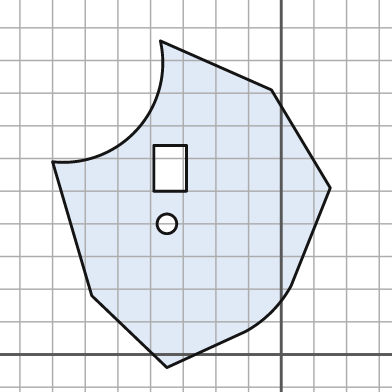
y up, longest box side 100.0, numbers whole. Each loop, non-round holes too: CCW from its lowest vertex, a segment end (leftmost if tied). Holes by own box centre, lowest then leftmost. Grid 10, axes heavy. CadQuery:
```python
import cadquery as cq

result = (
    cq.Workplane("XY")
    .moveTo(-35.0, -4.0)
    .lineTo(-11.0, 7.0)
    .threePointArc((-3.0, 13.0), (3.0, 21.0))
    .lineTo(15.0, 51.0)
    .lineTo(-3.0, 81.0)
    .lineTo(-37.0, 96.0)
    .threePointArc((-44.0, 69.0), (-70.0, 59.0))
    .lineTo(-58.0, 18.0)
    .close()
    .moveTo(-35.0, 40.0)
    .circle(3.0)
    .moveTo(-39.0, 50.0)
    .lineTo(-29.0, 50.0)
    .lineTo(-29.0, 64.0)
    .lineTo(-39.0, 64.0)
    .close()
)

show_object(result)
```